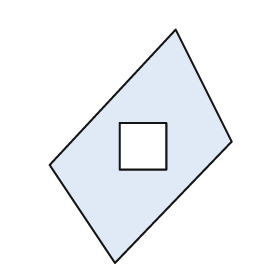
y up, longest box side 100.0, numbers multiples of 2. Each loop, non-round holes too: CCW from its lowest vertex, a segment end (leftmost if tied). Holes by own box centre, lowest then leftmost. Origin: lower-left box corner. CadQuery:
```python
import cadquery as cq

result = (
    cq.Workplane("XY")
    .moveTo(28.0, 0.0)
    .lineTo(78.0, 52.0)
    .lineTo(54.0, 100.0)
    .lineTo(0.0, 42.0)
    .close()
    .moveTo(30.0, 40.0)
    .lineTo(50.0, 40.0)
    .lineTo(50.0, 60.0)
    .lineTo(30.0, 60.0)
    .close()
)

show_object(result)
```